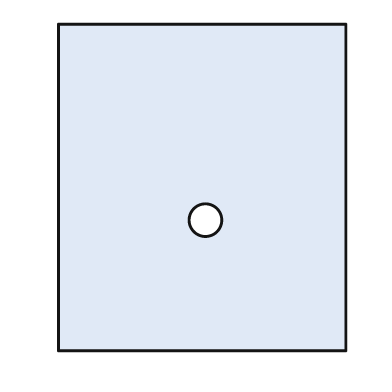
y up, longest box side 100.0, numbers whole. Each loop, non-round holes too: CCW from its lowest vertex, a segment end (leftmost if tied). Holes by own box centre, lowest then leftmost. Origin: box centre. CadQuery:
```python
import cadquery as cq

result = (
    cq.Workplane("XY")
    .moveTo(-44.0, -50.0)
    .lineTo(44.0, -50.0)
    .lineTo(44.0, 50.0)
    .lineTo(-44.0, 50.0)
    .close()
    .moveTo(1.0, -10.0)
    .circle(5.0)
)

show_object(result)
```